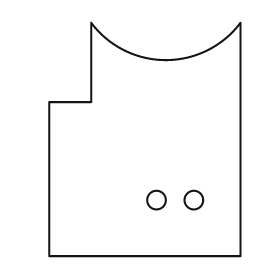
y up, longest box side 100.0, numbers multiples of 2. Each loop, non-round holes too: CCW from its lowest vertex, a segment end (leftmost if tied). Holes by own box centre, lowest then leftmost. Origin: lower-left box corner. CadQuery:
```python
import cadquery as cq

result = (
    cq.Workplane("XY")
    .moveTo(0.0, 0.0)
    .lineTo(82.0, 0.0)
    .lineTo(82.0, 100.0)
    .threePointArc((50.0, 84.0), (18.0, 100.0))
    .lineTo(18.0, 66.0)
    .lineTo(0.0, 66.0)
    .close()
    .moveTo(46.0, 24.0)
    .circle(4.0)
    .moveTo(62.0, 24.0)
    .circle(4.0)
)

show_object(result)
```